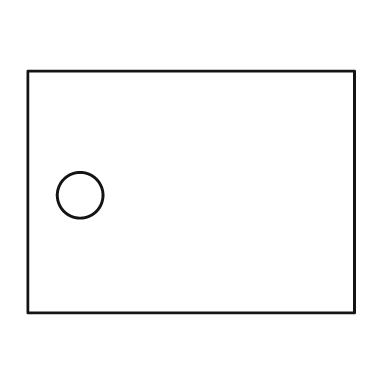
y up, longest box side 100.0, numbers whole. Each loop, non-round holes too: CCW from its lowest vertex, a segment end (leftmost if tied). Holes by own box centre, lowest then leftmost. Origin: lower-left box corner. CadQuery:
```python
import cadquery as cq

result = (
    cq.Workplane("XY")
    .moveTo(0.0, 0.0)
    .lineTo(100.0, 0.0)
    .lineTo(100.0, 74.0)
    .lineTo(0.0, 74.0)
    .close()
    .moveTo(16.0, 36.0)
    .circle(7.0)
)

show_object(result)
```